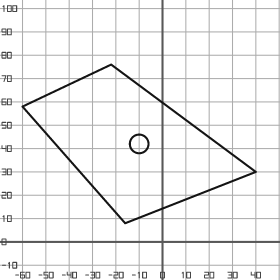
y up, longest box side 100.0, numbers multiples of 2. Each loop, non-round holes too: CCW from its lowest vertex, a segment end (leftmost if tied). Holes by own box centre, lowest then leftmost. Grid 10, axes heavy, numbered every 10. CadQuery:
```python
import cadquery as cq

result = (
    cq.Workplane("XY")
    .moveTo(-16.0, 8.0)
    .lineTo(40.0, 30.0)
    .lineTo(-22.0, 76.0)
    .lineTo(-60.0, 58.0)
    .close()
    .moveTo(-10.0, 42.0)
    .circle(4.0)
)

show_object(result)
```